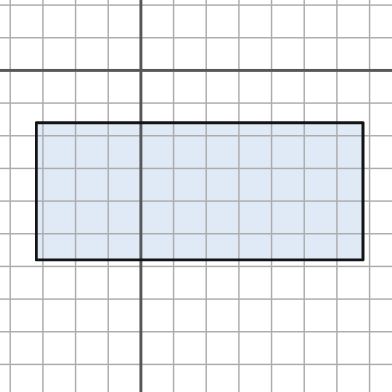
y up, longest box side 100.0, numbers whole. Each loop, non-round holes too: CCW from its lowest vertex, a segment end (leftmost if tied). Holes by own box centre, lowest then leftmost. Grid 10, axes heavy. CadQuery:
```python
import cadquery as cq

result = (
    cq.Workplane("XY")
    .moveTo(-32.0, -58.0)
    .lineTo(68.0, -58.0)
    .lineTo(68.0, -16.0)
    .lineTo(-32.0, -16.0)
    .close()
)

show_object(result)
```